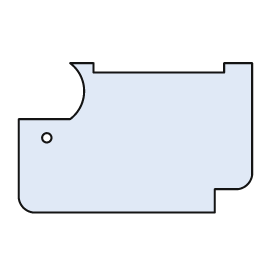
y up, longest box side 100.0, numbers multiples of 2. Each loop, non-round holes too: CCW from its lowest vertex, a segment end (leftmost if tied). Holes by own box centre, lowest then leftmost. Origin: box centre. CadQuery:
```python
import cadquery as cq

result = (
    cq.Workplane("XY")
    .moveTo(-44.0, -32.0)
    .lineTo(34.0, -32.0)
    .lineTo(34.0, -22.0)
    .lineTo(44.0, -22.0)
    .threePointArc((48.0, -20.0), (50.0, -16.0))
    .lineTo(50.0, 32.0)
    .lineTo(38.0, 32.0)
    .lineTo(38.0, 28.0)
    .lineTo(-18.0, 28.0)
    .lineTo(-18.0, 32.0)
    .lineTo(-28.0, 32.0)
    .threePointArc((-22.0, 20.0), (-28.0, 8.0))
    .lineTo(-50.0, 8.0)
    .lineTo(-50.0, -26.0)
    .threePointArc((-48.0, -30.0), (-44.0, -32.0))
    .close()
    .moveTo(-38.0, 0.0)
    .circle(2.0)
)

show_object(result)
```